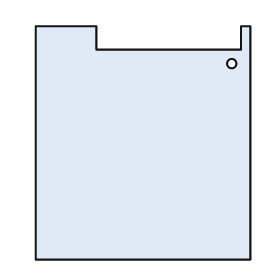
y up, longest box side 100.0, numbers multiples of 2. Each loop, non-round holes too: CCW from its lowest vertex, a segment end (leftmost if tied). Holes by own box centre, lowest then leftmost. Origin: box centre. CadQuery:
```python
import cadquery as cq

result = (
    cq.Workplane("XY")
    .moveTo(-46.0, -50.0)
    .lineTo(46.0, -50.0)
    .lineTo(46.0, 50.0)
    .lineTo(42.0, 50.0)
    .lineTo(42.0, 40.0)
    .lineTo(-20.0, 40.0)
    .lineTo(-20.0, 50.0)
    .lineTo(-46.0, 50.0)
    .close()
    .moveTo(38.0, 34.0)
    .circle(2.0)
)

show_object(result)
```